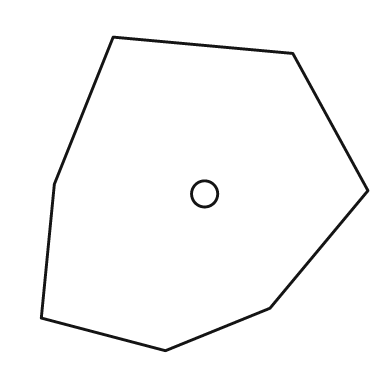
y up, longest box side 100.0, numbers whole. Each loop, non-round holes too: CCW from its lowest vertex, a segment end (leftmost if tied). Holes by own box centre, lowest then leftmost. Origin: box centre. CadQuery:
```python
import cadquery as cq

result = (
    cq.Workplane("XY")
    .moveTo(-12.0, -48.0)
    .lineTo(20.0, -35.0)
    .lineTo(50.0, 1.0)
    .lineTo(27.0, 43.0)
    .lineTo(-28.0, 48.0)
    .lineTo(-46.0, 3.0)
    .lineTo(-50.0, -38.0)
    .close()
    .moveTo(0.0, 0.0)
    .circle(4.0)
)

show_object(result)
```